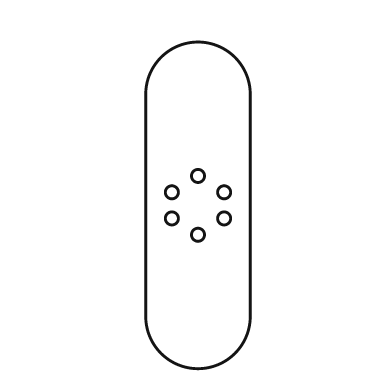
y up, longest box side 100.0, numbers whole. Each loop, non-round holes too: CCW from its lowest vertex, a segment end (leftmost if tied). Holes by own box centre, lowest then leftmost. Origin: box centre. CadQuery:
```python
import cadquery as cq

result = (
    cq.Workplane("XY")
    .moveTo(-16.0, -34.0)
    .threePointArc((0.0, -50.0), (16.0, -34.0))
    .lineTo(16.0, 34.0)
    .threePointArc((0.0, 50.0), (-16.0, 34.0))
    .close()
    .moveTo(0.0, -9.0)
    .circle(2.0)
    .moveTo(-8.0, -4.0)
    .circle(2.0)
    .moveTo(8.0, -4.0)
    .circle(2.0)
    .moveTo(-8.0, 4.0)
    .circle(2.0)
    .moveTo(8.0, 4.0)
    .circle(2.0)
    .moveTo(0.0, 9.0)
    .circle(2.0)
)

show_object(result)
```